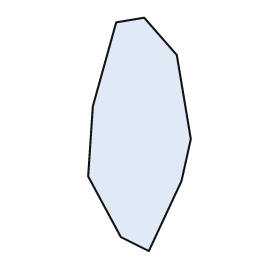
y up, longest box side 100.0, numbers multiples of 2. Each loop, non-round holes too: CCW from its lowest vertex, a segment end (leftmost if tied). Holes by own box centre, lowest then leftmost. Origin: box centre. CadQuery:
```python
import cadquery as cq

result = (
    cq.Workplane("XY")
    .moveTo(4.0, -50.0)
    .lineTo(18.0, -20.0)
    .lineTo(22.0, -2.0)
    .lineTo(16.0, 34.0)
    .lineTo(2.0, 50.0)
    .lineTo(-10.0, 48.0)
    .lineTo(-20.0, 12.0)
    .lineTo(-22.0, -18.0)
    .lineTo(-8.0, -44.0)
    .close()
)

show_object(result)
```